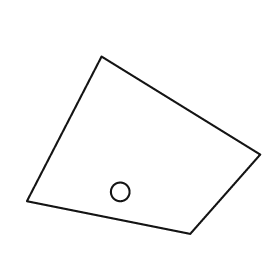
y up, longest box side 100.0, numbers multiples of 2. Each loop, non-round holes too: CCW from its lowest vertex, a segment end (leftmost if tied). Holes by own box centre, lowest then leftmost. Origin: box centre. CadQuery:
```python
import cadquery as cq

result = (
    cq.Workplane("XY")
    .moveTo(20.0, -38.0)
    .lineTo(50.0, -4.0)
    .lineTo(-18.0, 38.0)
    .lineTo(-50.0, -24.0)
    .close()
    .moveTo(-10.0, -20.0)
    .circle(4.0)
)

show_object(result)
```